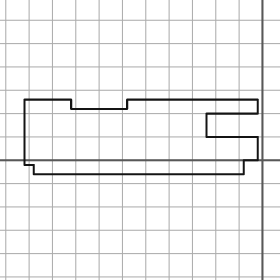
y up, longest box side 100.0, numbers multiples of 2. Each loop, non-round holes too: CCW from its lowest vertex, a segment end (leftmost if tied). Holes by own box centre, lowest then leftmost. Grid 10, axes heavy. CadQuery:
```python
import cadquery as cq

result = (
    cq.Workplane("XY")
    .moveTo(-98.0, -6.0)
    .lineTo(-8.0, -6.0)
    .lineTo(-8.0, 0.0)
    .lineTo(-2.0, 0.0)
    .lineTo(-2.0, 10.0)
    .lineTo(-24.0, 10.0)
    .lineTo(-24.0, 20.0)
    .lineTo(-2.0, 20.0)
    .lineTo(-2.0, 26.0)
    .lineTo(-58.0, 26.0)
    .lineTo(-58.0, 22.0)
    .lineTo(-82.0, 22.0)
    .lineTo(-82.0, 26.0)
    .lineTo(-102.0, 26.0)
    .lineTo(-102.0, -2.0)
    .lineTo(-98.0, -2.0)
    .close()
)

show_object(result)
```